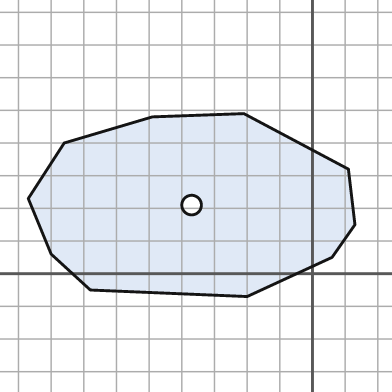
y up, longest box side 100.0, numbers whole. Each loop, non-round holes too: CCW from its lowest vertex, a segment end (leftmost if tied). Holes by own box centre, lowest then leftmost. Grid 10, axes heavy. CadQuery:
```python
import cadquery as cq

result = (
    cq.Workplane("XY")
    .moveTo(-20.0, -7.0)
    .lineTo(6.0, 5.0)
    .lineTo(13.0, 15.0)
    .lineTo(11.0, 32.0)
    .lineTo(-21.0, 49.0)
    .lineTo(-49.0, 48.0)
    .lineTo(-76.0, 40.0)
    .lineTo(-87.0, 23.0)
    .lineTo(-80.0, 6.0)
    .lineTo(-68.0, -5.0)
    .close()
    .moveTo(-37.0, 21.0)
    .circle(3.0)
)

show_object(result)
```